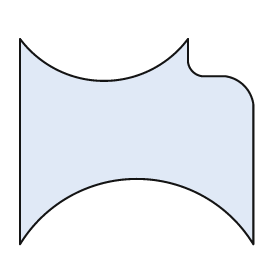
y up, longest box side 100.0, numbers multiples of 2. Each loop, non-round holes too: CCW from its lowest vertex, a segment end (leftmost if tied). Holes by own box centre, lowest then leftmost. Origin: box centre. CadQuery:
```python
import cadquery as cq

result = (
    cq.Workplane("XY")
    .moveTo(-50.0, -44.0)
    .threePointArc((0.0, -16.0), (50.0, -44.0))
    .lineTo(50.0, 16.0)
    .threePointArc((46.0, 24.0), (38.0, 28.0))
    .lineTo(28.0, 28.0)
    .threePointArc((24.0, 30.0), (22.0, 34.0))
    .lineTo(22.0, 44.0)
    .threePointArc((-14.0, 26.0), (-50.0, 44.0))
    .close()
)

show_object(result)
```